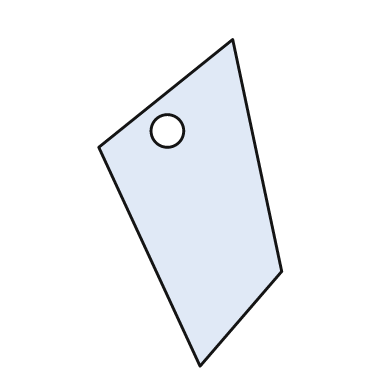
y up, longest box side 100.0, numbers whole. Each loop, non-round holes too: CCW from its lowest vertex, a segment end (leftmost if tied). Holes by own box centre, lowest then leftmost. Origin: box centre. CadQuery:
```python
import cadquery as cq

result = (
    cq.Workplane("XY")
    .moveTo(3.0, -50.0)
    .lineTo(28.0, -21.0)
    .lineTo(13.0, 50.0)
    .lineTo(-28.0, 17.0)
    .close()
    .moveTo(-7.0, 22.0)
    .circle(5.0)
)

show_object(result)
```